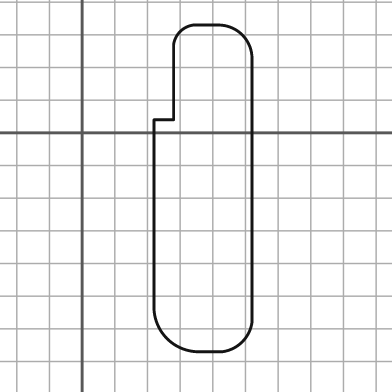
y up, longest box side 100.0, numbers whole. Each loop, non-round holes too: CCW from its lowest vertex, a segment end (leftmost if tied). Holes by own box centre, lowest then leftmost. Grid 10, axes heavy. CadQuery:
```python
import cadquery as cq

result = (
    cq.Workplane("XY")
    .moveTo(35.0, -67.0)
    .lineTo(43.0, -67.0)
    .threePointArc((49.0, -64.0), (52.0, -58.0))
    .lineTo(52.0, 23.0)
    .threePointArc((49.0, 30.0), (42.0, 33.0))
    .lineTo(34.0, 33.0)
    .threePointArc((30.0, 31.0), (28.0, 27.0))
    .lineTo(28.0, 4.0)
    .lineTo(22.0, 4.0)
    .lineTo(22.0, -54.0)
    .threePointArc((26.0, -63.0), (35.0, -67.0))
    .close()
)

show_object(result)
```